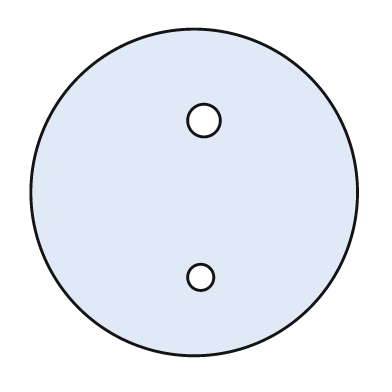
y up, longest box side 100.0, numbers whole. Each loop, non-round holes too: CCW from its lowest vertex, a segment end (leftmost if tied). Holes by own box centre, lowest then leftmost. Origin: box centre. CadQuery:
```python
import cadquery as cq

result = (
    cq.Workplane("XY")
    .moveTo(0.0, 0.0)
    .circle(50.0)
    .moveTo(2.0, -26.0)
    .circle(4.0)
    .moveTo(3.0, 22.0)
    .circle(5.0)
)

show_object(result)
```